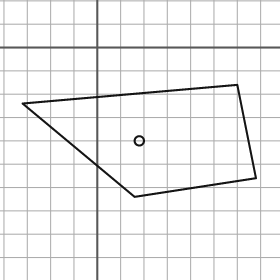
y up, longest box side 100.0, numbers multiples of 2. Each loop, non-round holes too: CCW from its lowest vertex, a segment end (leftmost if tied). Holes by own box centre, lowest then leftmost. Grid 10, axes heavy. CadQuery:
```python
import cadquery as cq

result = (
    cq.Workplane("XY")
    .moveTo(16.0, -64.0)
    .lineTo(68.0, -56.0)
    .lineTo(60.0, -16.0)
    .lineTo(-32.0, -24.0)
    .close()
    .moveTo(18.0, -40.0)
    .circle(2.0)
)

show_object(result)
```